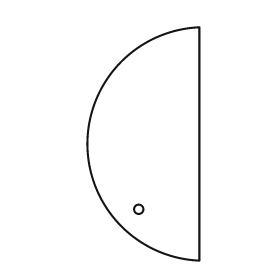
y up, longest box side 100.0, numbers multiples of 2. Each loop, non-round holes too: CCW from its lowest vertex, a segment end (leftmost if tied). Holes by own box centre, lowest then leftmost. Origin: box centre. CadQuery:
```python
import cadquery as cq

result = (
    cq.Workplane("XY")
    .moveTo(24.0, -50.0)
    .lineTo(24.0, 50.0)
    .threePointArc((-24.0, 0.0), (24.0, -50.0))
    .close()
    .moveTo(-2.0, -28.0)
    .circle(2.0)
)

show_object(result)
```